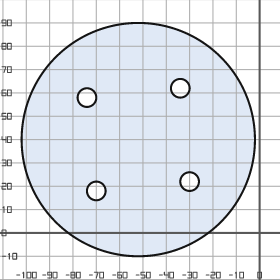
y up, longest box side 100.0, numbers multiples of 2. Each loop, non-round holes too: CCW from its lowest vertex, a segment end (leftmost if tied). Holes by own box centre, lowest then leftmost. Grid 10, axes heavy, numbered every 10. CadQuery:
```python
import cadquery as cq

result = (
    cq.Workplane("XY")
    .moveTo(-52.0, 40.0)
    .circle(50.0)
    .moveTo(-70.0, 18.0)
    .circle(4.0)
    .moveTo(-30.0, 22.0)
    .circle(4.0)
    .moveTo(-74.0, 58.0)
    .circle(4.0)
    .moveTo(-34.0, 62.0)
    .circle(4.0)
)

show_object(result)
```